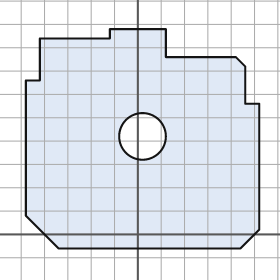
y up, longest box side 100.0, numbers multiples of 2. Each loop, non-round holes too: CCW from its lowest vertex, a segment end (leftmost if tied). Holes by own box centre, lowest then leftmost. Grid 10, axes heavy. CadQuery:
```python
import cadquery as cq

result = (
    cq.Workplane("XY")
    .moveTo(-34.0, -6.0)
    .lineTo(44.0, -6.0)
    .lineTo(52.0, 2.0)
    .lineTo(52.0, 56.0)
    .lineTo(46.0, 56.0)
    .lineTo(46.0, 72.0)
    .lineTo(42.0, 76.0)
    .lineTo(12.0, 76.0)
    .lineTo(12.0, 88.0)
    .lineTo(-12.0, 88.0)
    .lineTo(-12.0, 84.0)
    .lineTo(-42.0, 84.0)
    .lineTo(-42.0, 66.0)
    .lineTo(-48.0, 66.0)
    .lineTo(-48.0, 8.0)
    .close()
    .moveTo(2.0, 42.0)
    .circle(10.0)
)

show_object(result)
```